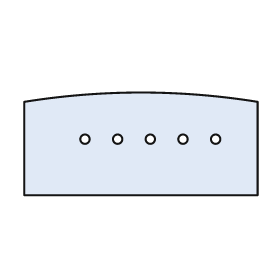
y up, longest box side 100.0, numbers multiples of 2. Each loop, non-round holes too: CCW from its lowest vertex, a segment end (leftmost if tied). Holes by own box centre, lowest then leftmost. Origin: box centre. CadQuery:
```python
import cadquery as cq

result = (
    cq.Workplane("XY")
    .moveTo(-50.0, -22.0)
    .lineTo(50.0, -22.0)
    .lineTo(50.0, 18.0)
    .threePointArc((0.0, 22.0), (-50.0, 18.0))
    .close()
    .moveTo(-24.0, 2.0)
    .circle(2.0)
    .moveTo(-10.0, 2.0)
    .circle(2.0)
    .moveTo(4.0, 2.0)
    .circle(2.0)
    .moveTo(18.0, 2.0)
    .circle(2.0)
    .moveTo(32.0, 2.0)
    .circle(2.0)
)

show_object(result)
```